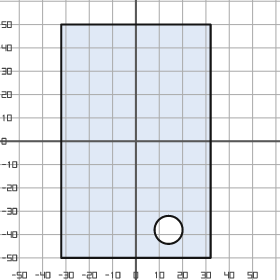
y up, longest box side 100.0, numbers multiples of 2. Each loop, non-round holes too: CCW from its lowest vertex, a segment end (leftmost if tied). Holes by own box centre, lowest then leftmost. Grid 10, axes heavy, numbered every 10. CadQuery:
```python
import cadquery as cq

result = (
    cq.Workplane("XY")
    .moveTo(-32.0, -50.0)
    .lineTo(32.0, -50.0)
    .lineTo(32.0, 50.0)
    .lineTo(-32.0, 50.0)
    .close()
    .moveTo(14.0, -38.0)
    .circle(6.0)
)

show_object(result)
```